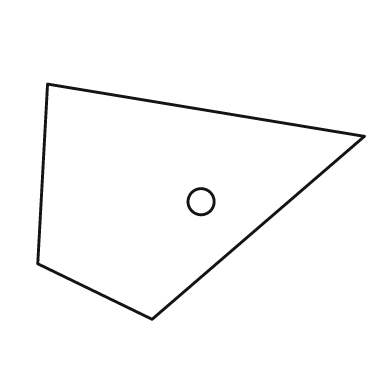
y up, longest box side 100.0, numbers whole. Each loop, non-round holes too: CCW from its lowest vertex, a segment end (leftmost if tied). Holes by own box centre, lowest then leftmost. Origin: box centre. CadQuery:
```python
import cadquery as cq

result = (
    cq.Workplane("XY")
    .moveTo(-15.0, -36.0)
    .lineTo(50.0, 20.0)
    .lineTo(-47.0, 36.0)
    .lineTo(-50.0, -19.0)
    .close()
    .moveTo(0.0, 0.0)
    .circle(4.0)
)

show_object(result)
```